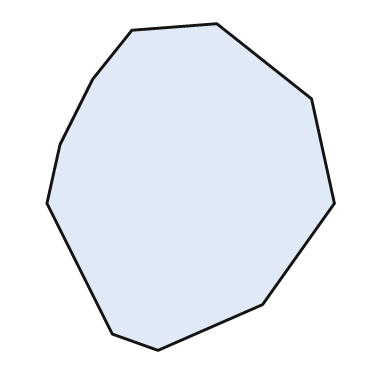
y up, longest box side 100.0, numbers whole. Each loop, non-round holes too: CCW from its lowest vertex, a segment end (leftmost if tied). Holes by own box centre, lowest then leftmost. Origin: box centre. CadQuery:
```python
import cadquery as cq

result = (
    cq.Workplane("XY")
    .moveTo(-10.0, -50.0)
    .lineTo(22.0, -36.0)
    .lineTo(44.0, -5.0)
    .lineTo(37.0, 27.0)
    .lineTo(8.0, 50.0)
    .lineTo(-18.0, 48.0)
    .lineTo(-30.0, 33.0)
    .lineTo(-40.0, 13.0)
    .lineTo(-44.0, -5.0)
    .lineTo(-24.0, -45.0)
    .close()
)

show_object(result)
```